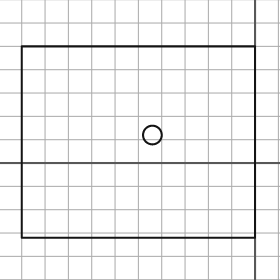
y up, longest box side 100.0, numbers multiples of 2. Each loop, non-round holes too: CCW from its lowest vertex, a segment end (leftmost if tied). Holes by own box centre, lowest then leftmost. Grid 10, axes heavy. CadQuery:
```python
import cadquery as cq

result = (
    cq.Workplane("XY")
    .moveTo(-100.0, -32.0)
    .lineTo(0.0, -32.0)
    .lineTo(0.0, 50.0)
    .lineTo(-100.0, 50.0)
    .close()
    .moveTo(-44.0, 12.0)
    .circle(4.0)
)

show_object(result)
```